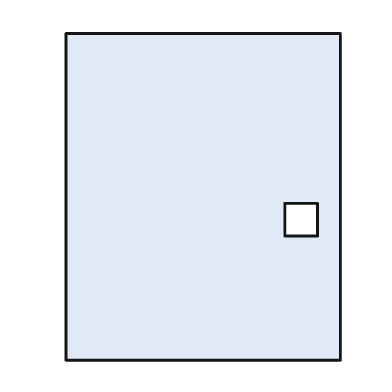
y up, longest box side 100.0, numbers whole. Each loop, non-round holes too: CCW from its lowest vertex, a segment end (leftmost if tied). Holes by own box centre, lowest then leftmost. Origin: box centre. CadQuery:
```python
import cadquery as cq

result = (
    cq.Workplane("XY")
    .moveTo(-42.0, -50.0)
    .lineTo(42.0, -50.0)
    .lineTo(42.0, 50.0)
    .lineTo(-42.0, 50.0)
    .close()
    .moveTo(25.0, -12.0)
    .lineTo(35.0, -12.0)
    .lineTo(35.0, -2.0)
    .lineTo(25.0, -2.0)
    .close()
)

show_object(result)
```